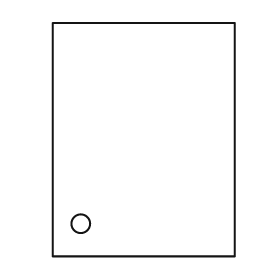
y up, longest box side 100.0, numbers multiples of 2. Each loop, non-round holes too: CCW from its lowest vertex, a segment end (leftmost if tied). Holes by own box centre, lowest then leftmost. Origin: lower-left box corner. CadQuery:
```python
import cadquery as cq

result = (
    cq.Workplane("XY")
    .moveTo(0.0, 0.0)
    .lineTo(78.0, 0.0)
    .lineTo(78.0, 100.0)
    .lineTo(0.0, 100.0)
    .close()
    .moveTo(12.0, 14.0)
    .circle(4.0)
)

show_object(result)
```